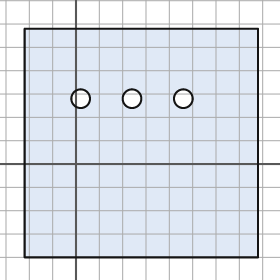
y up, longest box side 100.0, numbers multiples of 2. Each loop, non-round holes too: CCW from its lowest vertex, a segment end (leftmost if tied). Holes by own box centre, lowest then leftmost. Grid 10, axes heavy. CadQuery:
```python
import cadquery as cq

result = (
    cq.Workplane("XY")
    .moveTo(-22.0, -40.0)
    .lineTo(78.0, -40.0)
    .lineTo(78.0, 58.0)
    .lineTo(-22.0, 58.0)
    .close()
    .moveTo(2.0, 28.0)
    .circle(4.0)
    .moveTo(24.0, 28.0)
    .circle(4.0)
    .moveTo(46.0, 28.0)
    .circle(4.0)
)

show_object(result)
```